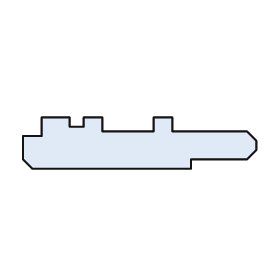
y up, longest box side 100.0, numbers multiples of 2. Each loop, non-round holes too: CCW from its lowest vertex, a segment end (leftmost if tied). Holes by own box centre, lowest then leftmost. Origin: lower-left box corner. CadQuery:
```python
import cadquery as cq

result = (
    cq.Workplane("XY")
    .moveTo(4.0, 0.0)
    .lineTo(72.0, 0.0)
    .lineTo(72.0, 4.0)
    .lineTo(96.0, 4.0)
    .lineTo(100.0, 8.0)
    .lineTo(100.0, 12.0)
    .lineTo(96.0, 16.0)
    .lineTo(64.0, 16.0)
    .lineTo(64.0, 22.0)
    .lineTo(56.0, 22.0)
    .lineTo(56.0, 16.0)
    .lineTo(34.0, 16.0)
    .lineTo(34.0, 22.0)
    .lineTo(26.0, 22.0)
    .lineTo(26.0, 18.0)
    .lineTo(20.0, 18.0)
    .lineTo(20.0, 22.0)
    .lineTo(8.0, 22.0)
    .lineTo(8.0, 14.0)
    .lineTo(0.0, 14.0)
    .lineTo(0.0, 4.0)
    .close()
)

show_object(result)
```